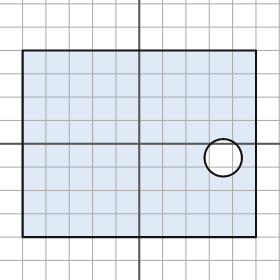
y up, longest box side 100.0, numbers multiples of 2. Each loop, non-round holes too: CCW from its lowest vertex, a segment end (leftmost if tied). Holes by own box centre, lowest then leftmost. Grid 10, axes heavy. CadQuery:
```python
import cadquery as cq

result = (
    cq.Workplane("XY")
    .moveTo(-50.0, -40.0)
    .lineTo(50.0, -40.0)
    .lineTo(50.0, 40.0)
    .lineTo(-50.0, 40.0)
    .close()
    .moveTo(36.0, -6.0)
    .circle(8.0)
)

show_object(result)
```